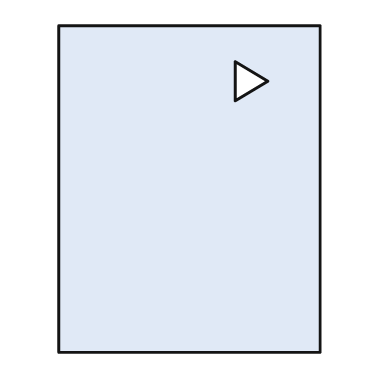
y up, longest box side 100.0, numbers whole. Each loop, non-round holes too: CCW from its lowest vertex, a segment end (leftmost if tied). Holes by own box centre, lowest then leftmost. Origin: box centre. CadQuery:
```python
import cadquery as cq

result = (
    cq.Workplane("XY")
    .moveTo(-40.0, -50.0)
    .lineTo(40.0, -50.0)
    .lineTo(40.0, 50.0)
    .lineTo(-40.0, 50.0)
    .close()
    .moveTo(14.0, 27.0)
    .lineTo(24.0, 33.0)
    .lineTo(14.0, 39.0)
    .close()
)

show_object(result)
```